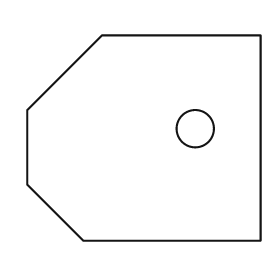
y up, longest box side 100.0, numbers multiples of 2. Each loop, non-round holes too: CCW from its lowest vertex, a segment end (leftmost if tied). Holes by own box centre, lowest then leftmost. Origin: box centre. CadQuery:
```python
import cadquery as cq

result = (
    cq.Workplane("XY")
    .moveTo(-26.0, -44.0)
    .lineTo(50.0, -44.0)
    .lineTo(50.0, 44.0)
    .lineTo(-18.0, 44.0)
    .lineTo(-50.0, 12.0)
    .lineTo(-50.0, -20.0)
    .close()
    .moveTo(22.0, 4.0)
    .circle(8.0)
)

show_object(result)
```